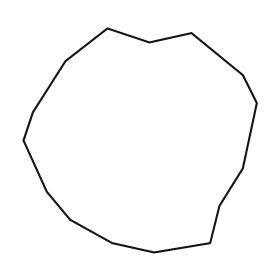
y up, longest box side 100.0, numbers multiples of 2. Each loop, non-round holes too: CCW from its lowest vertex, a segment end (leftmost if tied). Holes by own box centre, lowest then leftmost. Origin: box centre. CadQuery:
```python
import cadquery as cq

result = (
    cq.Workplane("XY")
    .moveTo(6.0, -48.0)
    .lineTo(30.0, -44.0)
    .lineTo(34.0, -28.0)
    .lineTo(44.0, -12.0)
    .lineTo(50.0, 16.0)
    .lineTo(44.0, 28.0)
    .lineTo(22.0, 46.0)
    .lineTo(4.0, 42.0)
    .lineTo(-14.0, 48.0)
    .lineTo(-32.0, 34.0)
    .lineTo(-46.0, 12.0)
    .lineTo(-50.0, 0.0)
    .lineTo(-40.0, -22.0)
    .lineTo(-30.0, -34.0)
    .lineTo(-12.0, -44.0)
    .close()
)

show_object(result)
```